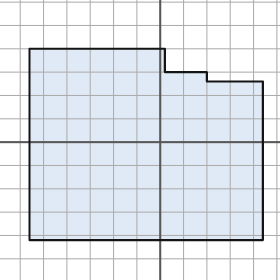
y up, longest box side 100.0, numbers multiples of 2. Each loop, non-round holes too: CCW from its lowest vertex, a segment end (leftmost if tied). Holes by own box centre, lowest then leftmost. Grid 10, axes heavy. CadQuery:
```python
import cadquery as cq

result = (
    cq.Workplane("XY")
    .moveTo(-56.0, -42.0)
    .lineTo(44.0, -42.0)
    .lineTo(44.0, 26.0)
    .lineTo(20.0, 26.0)
    .lineTo(20.0, 30.0)
    .lineTo(2.0, 30.0)
    .lineTo(2.0, 40.0)
    .lineTo(-56.0, 40.0)
    .close()
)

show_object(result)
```